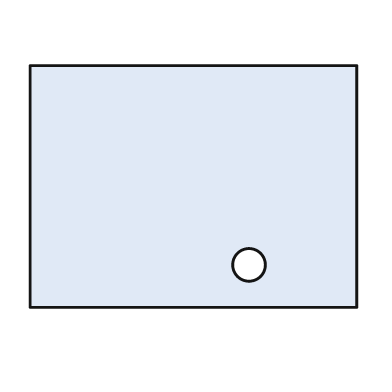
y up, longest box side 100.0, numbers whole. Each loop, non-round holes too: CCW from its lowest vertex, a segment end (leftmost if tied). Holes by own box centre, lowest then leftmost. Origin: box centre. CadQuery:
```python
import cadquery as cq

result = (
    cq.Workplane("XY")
    .moveTo(-50.0, -37.0)
    .lineTo(50.0, -37.0)
    .lineTo(50.0, 37.0)
    .lineTo(-50.0, 37.0)
    .close()
    .moveTo(17.0, -24.0)
    .circle(5.0)
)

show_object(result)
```